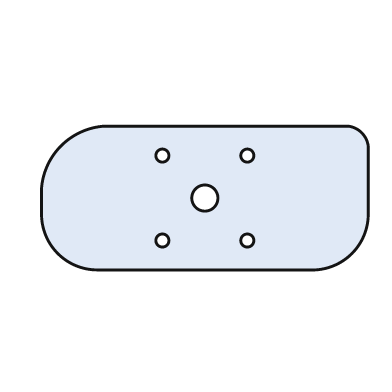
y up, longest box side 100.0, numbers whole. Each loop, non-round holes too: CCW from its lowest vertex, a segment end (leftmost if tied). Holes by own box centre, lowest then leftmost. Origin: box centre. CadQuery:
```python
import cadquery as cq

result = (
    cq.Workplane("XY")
    .moveTo(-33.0, -22.0)
    .lineTo(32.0, -22.0)
    .threePointArc((45.0, -17.0), (50.0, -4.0))
    .lineTo(50.0, 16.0)
    .threePointArc((48.0, 20.0), (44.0, 22.0))
    .lineTo(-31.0, 22.0)
    .threePointArc((-44.0, 16.0), (-50.0, 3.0))
    .lineTo(-50.0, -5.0)
    .threePointArc((-45.0, -17.0), (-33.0, -22.0))
    .close()
    .moveTo(-13.0, -13.0)
    .circle(2.0)
    .moveTo(13.0, -13.0)
    .circle(2.0)
    .moveTo(0.0, 0.0)
    .circle(4.0)
    .moveTo(-13.0, 13.0)
    .circle(2.0)
    .moveTo(13.0, 13.0)
    .circle(2.0)
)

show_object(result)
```